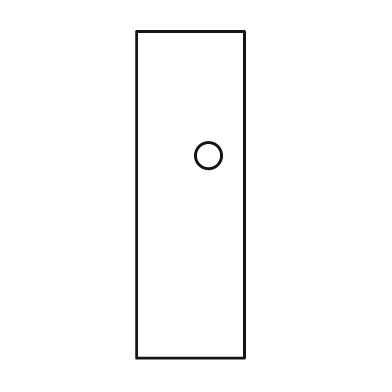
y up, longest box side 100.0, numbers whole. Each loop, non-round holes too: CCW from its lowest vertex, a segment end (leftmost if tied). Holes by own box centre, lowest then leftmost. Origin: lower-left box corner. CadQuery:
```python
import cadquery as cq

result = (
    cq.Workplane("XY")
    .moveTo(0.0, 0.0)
    .lineTo(33.0, 0.0)
    .lineTo(33.0, 100.0)
    .lineTo(0.0, 100.0)
    .close()
    .moveTo(22.0, 62.0)
    .circle(4.0)
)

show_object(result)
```